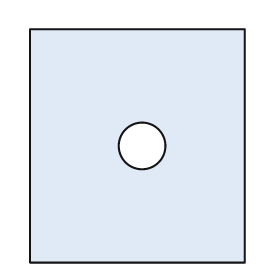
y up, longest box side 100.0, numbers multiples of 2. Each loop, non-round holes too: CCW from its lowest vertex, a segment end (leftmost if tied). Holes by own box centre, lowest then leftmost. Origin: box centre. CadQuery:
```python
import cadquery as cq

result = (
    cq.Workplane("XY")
    .moveTo(-46.0, -50.0)
    .lineTo(46.0, -50.0)
    .lineTo(46.0, 50.0)
    .lineTo(-46.0, 50.0)
    .close()
    .moveTo(2.0, 0.0)
    .circle(10.0)
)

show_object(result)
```